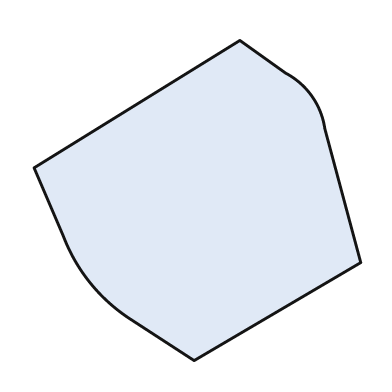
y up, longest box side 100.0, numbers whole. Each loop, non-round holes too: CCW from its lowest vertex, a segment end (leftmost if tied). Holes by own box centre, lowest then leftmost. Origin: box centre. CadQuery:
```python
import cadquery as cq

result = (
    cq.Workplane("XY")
    .moveTo(-1.0, -49.0)
    .lineTo(50.0, -19.0)
    .lineTo(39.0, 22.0)
    .threePointArc((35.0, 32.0), (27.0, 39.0))
    .lineTo(13.0, 49.0)
    .lineTo(-50.0, 10.0)
    .lineTo(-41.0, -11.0)
    .threePointArc((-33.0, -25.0), (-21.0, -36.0))
    .close()
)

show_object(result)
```